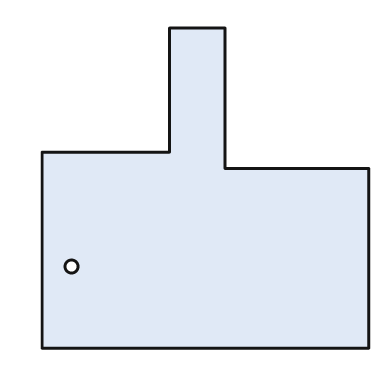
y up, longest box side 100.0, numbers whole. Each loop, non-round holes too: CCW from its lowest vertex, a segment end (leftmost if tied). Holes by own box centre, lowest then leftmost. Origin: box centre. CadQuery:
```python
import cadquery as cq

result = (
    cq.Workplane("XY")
    .moveTo(-50.0, -49.0)
    .lineTo(50.0, -49.0)
    .lineTo(50.0, 6.0)
    .lineTo(6.0, 6.0)
    .lineTo(6.0, 49.0)
    .lineTo(-11.0, 49.0)
    .lineTo(-11.0, 11.0)
    .lineTo(-50.0, 11.0)
    .close()
    .moveTo(-41.0, -24.0)
    .circle(2.0)
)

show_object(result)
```